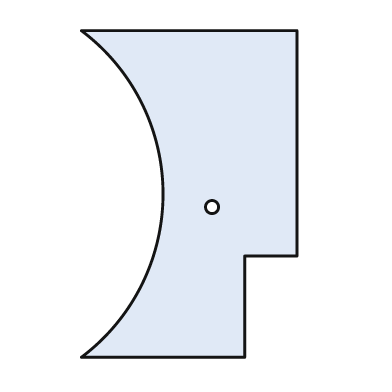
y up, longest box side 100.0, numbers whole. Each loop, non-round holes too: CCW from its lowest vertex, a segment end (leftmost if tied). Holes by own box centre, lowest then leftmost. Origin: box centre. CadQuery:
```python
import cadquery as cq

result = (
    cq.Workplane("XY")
    .moveTo(-33.0, -50.0)
    .lineTo(17.0, -50.0)
    .lineTo(17.0, -19.0)
    .lineTo(33.0, -19.0)
    .lineTo(33.0, 50.0)
    .lineTo(-33.0, 50.0)
    .threePointArc((-8.0, 0.0), (-33.0, -50.0))
    .close()
    .moveTo(7.0, -4.0)
    .circle(2.0)
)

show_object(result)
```